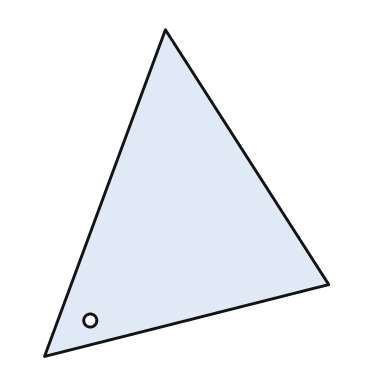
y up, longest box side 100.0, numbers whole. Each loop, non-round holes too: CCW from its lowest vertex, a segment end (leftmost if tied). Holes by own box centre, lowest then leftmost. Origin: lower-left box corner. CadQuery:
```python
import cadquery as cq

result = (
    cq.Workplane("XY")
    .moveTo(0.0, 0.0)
    .lineTo(87.0, 22.0)
    .lineTo(37.0, 100.0)
    .close()
    .moveTo(14.0, 11.0)
    .circle(2.0)
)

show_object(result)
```